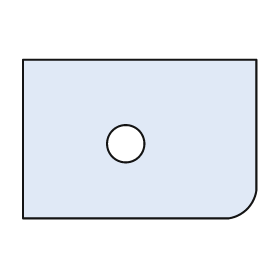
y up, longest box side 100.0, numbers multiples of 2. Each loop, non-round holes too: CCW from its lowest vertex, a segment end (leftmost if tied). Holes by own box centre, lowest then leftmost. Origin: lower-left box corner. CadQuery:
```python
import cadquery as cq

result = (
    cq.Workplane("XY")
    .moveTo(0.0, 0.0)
    .lineTo(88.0, 0.0)
    .threePointArc((96.0, 4.0), (100.0, 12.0))
    .lineTo(100.0, 68.0)
    .lineTo(0.0, 68.0)
    .close()
    .moveTo(44.0, 32.0)
    .circle(8.0)
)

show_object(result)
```